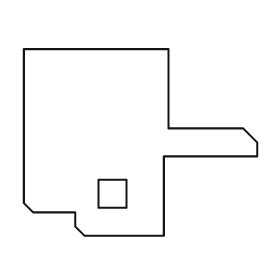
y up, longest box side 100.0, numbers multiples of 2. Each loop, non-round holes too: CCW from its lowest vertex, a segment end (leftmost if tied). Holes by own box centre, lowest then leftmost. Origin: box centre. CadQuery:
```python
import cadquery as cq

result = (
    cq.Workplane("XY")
    .moveTo(-24.0, -40.0)
    .lineTo(10.0, -40.0)
    .lineTo(10.0, -6.0)
    .lineTo(50.0, -6.0)
    .lineTo(50.0, 0.0)
    .lineTo(44.0, 6.0)
    .lineTo(12.0, 6.0)
    .lineTo(12.0, 40.0)
    .lineTo(-50.0, 40.0)
    .lineTo(-50.0, -26.0)
    .lineTo(-46.0, -30.0)
    .lineTo(-28.0, -30.0)
    .lineTo(-28.0, -36.0)
    .close()
    .moveTo(-18.0, -28.0)
    .lineTo(-6.0, -28.0)
    .lineTo(-6.0, -16.0)
    .lineTo(-18.0, -16.0)
    .close()
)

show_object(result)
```